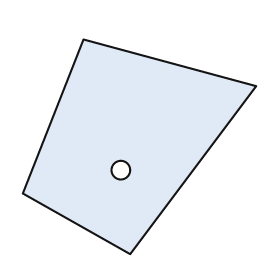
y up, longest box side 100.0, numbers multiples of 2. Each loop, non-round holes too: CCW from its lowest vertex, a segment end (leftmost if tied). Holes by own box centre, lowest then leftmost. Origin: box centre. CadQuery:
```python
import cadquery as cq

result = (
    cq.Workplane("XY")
    .moveTo(-4.0, -46.0)
    .lineTo(50.0, 26.0)
    .lineTo(-24.0, 46.0)
    .lineTo(-50.0, -20.0)
    .close()
    .moveTo(-8.0, -10.0)
    .circle(4.0)
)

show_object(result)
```